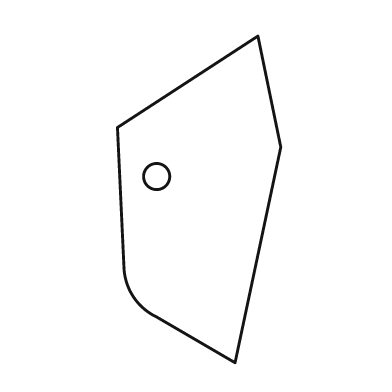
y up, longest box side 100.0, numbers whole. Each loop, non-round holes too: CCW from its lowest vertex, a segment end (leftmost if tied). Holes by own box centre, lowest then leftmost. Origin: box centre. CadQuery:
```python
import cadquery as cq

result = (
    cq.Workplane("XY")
    .moveTo(11.0, -50.0)
    .lineTo(25.0, 16.0)
    .lineTo(18.0, 50.0)
    .lineTo(-25.0, 22.0)
    .lineTo(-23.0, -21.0)
    .threePointArc((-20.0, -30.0), (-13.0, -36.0))
    .close()
    .moveTo(-13.0, 7.0)
    .circle(4.0)
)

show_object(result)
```